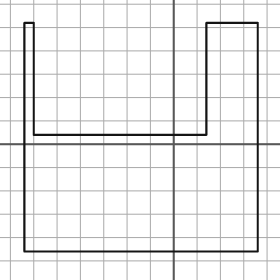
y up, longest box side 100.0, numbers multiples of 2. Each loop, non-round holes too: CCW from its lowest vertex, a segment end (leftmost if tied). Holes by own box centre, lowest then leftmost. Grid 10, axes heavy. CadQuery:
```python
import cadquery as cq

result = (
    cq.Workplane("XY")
    .moveTo(-64.0, -46.0)
    .lineTo(36.0, -46.0)
    .lineTo(36.0, 52.0)
    .lineTo(14.0, 52.0)
    .lineTo(14.0, 4.0)
    .lineTo(-60.0, 4.0)
    .lineTo(-60.0, 52.0)
    .lineTo(-64.0, 52.0)
    .close()
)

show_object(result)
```